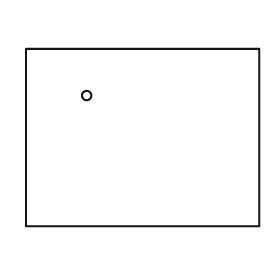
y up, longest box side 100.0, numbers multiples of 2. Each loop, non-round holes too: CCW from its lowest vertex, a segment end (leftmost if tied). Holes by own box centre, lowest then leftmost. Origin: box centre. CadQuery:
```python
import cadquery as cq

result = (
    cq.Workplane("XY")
    .moveTo(-50.0, -38.0)
    .lineTo(50.0, -38.0)
    .lineTo(50.0, 38.0)
    .lineTo(-50.0, 38.0)
    .close()
    .moveTo(-24.0, 18.0)
    .circle(2.0)
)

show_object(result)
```